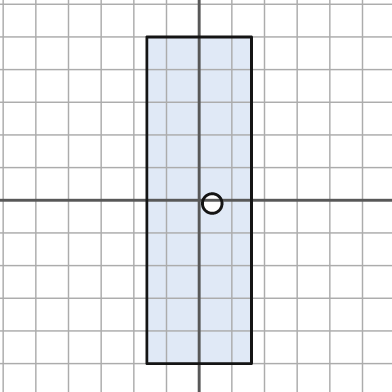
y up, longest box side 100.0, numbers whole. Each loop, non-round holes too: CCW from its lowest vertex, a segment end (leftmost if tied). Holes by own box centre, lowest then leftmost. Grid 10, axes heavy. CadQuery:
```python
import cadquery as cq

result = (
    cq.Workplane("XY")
    .moveTo(-16.0, -50.0)
    .lineTo(16.0, -50.0)
    .lineTo(16.0, 50.0)
    .lineTo(-16.0, 50.0)
    .close()
    .moveTo(4.0, -1.0)
    .circle(3.0)
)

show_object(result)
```